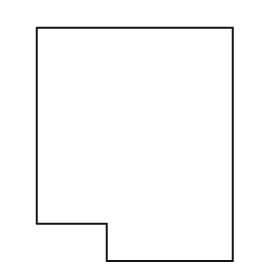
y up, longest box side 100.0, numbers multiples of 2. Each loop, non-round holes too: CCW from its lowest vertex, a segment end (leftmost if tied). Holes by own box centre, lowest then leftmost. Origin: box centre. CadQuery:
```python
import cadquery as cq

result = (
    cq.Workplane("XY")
    .moveTo(-12.0, -50.0)
    .lineTo(42.0, -50.0)
    .lineTo(42.0, 50.0)
    .lineTo(-42.0, 50.0)
    .lineTo(-42.0, -34.0)
    .lineTo(-12.0, -34.0)
    .close()
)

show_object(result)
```